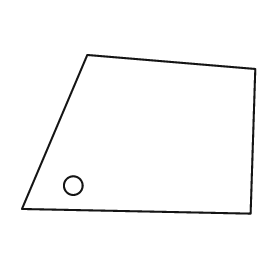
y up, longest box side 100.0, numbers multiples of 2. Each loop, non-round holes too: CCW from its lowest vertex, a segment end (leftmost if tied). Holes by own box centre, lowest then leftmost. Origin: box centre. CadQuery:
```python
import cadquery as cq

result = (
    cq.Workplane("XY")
    .moveTo(48.0, -34.0)
    .lineTo(50.0, 28.0)
    .lineTo(-22.0, 34.0)
    .lineTo(-50.0, -32.0)
    .close()
    .moveTo(-28.0, -22.0)
    .circle(4.0)
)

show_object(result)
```